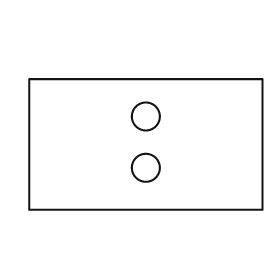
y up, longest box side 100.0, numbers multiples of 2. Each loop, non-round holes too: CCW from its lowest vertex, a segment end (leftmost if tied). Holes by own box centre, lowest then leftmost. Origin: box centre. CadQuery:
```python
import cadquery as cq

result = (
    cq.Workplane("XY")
    .moveTo(-50.0, -28.0)
    .lineTo(50.0, -28.0)
    .lineTo(50.0, 28.0)
    .lineTo(-50.0, 28.0)
    .close()
    .moveTo(0.0, -10.0)
    .circle(6.0)
    .moveTo(0.0, 12.0)
    .circle(6.0)
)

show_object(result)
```